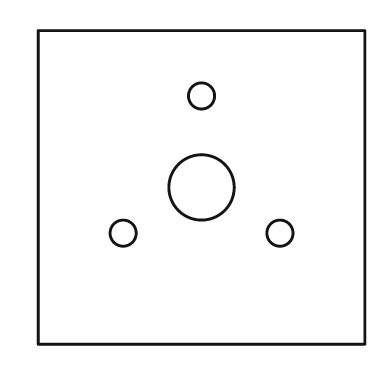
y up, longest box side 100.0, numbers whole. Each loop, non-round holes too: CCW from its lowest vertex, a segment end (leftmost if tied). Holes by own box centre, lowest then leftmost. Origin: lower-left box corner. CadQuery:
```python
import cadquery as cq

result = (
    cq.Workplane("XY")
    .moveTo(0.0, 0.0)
    .lineTo(100.0, 0.0)
    .lineTo(100.0, 96.0)
    .lineTo(0.0, 96.0)
    .close()
    .moveTo(26.0, 34.0)
    .circle(4.0)
    .moveTo(74.0, 34.0)
    .circle(4.0)
    .moveTo(50.0, 48.0)
    .circle(10.0)
    .moveTo(50.0, 76.0)
    .circle(4.0)
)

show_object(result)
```